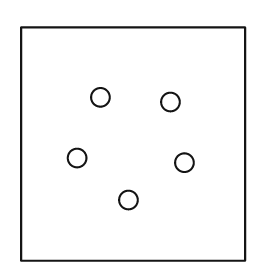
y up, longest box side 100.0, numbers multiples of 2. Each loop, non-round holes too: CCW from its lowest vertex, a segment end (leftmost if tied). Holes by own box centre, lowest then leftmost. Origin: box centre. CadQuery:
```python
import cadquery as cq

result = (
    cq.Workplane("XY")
    .moveTo(-48.0, -50.0)
    .lineTo(48.0, -50.0)
    .lineTo(48.0, 50.0)
    .lineTo(-48.0, 50.0)
    .close()
    .moveTo(-2.0, -24.0)
    .circle(4.0)
    .moveTo(22.0, -8.0)
    .circle(4.0)
    .moveTo(-24.0, -6.0)
    .circle(4.0)
    .moveTo(16.0, 18.0)
    .circle(4.0)
    .moveTo(-14.0, 20.0)
    .circle(4.0)
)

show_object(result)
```